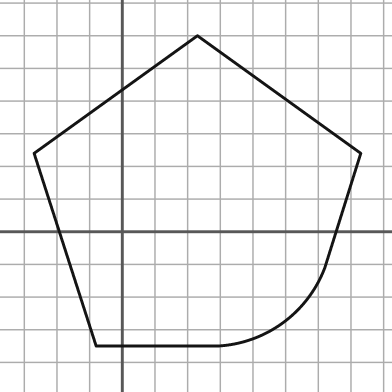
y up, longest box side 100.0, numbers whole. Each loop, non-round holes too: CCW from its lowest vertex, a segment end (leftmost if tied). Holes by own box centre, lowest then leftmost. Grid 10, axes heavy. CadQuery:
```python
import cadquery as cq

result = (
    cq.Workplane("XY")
    .moveTo(-8.0, -35.0)
    .lineTo(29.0, -35.0)
    .threePointArc((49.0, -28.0), (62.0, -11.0))
    .lineTo(73.0, 24.0)
    .lineTo(23.0, 60.0)
    .lineTo(-27.0, 24.0)
    .close()
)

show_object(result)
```